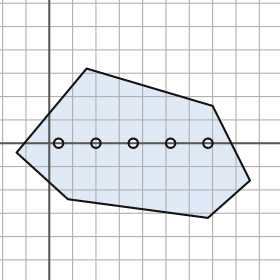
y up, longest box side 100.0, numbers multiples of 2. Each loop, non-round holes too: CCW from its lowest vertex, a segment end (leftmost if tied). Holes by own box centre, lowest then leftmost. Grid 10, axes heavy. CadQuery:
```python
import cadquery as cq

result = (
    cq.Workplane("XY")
    .moveTo(68.0, -32.0)
    .lineTo(86.0, -16.0)
    .lineTo(70.0, 16.0)
    .lineTo(16.0, 32.0)
    .lineTo(-14.0, -4.0)
    .lineTo(8.0, -24.0)
    .close()
    .moveTo(4.0, 0.0)
    .circle(2.0)
    .moveTo(20.0, 0.0)
    .circle(2.0)
    .moveTo(36.0, 0.0)
    .circle(2.0)
    .moveTo(52.0, 0.0)
    .circle(2.0)
    .moveTo(68.0, 0.0)
    .circle(2.0)
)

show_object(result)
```